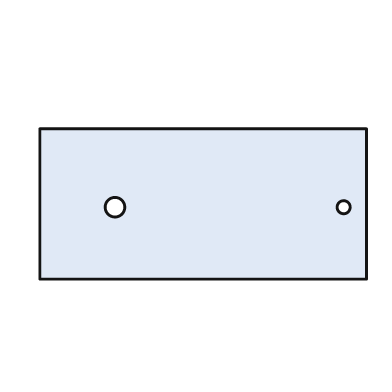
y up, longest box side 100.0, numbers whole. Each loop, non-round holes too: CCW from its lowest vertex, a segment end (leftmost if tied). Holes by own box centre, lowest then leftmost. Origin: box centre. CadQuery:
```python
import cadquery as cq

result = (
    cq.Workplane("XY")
    .moveTo(-50.0, -23.0)
    .lineTo(50.0, -23.0)
    .lineTo(50.0, 23.0)
    .lineTo(-50.0, 23.0)
    .close()
    .moveTo(-27.0, -1.0)
    .circle(3.0)
    .moveTo(43.0, -1.0)
    .circle(2.0)
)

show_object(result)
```